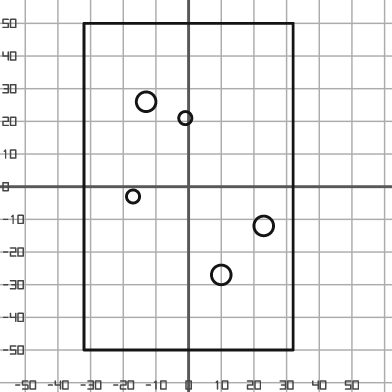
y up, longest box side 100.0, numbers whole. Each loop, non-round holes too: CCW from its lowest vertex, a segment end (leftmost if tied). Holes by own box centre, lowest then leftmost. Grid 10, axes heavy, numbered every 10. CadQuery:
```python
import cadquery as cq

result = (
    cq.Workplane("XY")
    .moveTo(-32.0, -50.0)
    .lineTo(32.0, -50.0)
    .lineTo(32.0, 50.0)
    .lineTo(-32.0, 50.0)
    .close()
    .moveTo(10.0, -27.0)
    .circle(3.0)
    .moveTo(23.0, -12.0)
    .circle(3.0)
    .moveTo(-17.0, -3.0)
    .circle(2.0)
    .moveTo(-1.0, 21.0)
    .circle(2.0)
    .moveTo(-13.0, 26.0)
    .circle(3.0)
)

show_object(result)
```